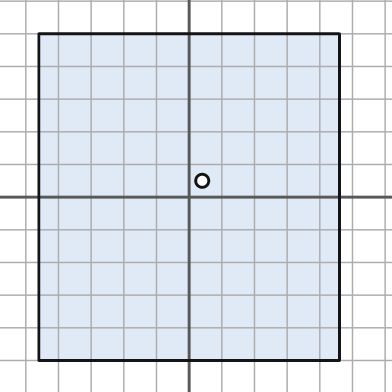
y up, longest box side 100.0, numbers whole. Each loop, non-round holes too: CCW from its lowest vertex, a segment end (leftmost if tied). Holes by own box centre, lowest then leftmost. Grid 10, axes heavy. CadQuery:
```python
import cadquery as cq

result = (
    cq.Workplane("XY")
    .moveTo(-46.0, -50.0)
    .lineTo(46.0, -50.0)
    .lineTo(46.0, 50.0)
    .lineTo(-46.0, 50.0)
    .close()
    .moveTo(4.0, 5.0)
    .circle(2.0)
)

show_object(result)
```